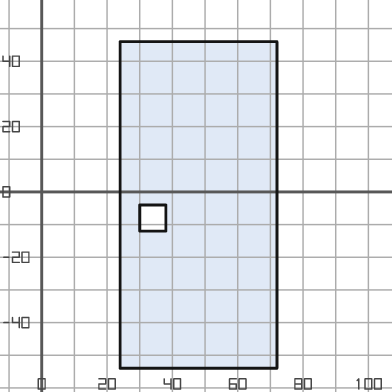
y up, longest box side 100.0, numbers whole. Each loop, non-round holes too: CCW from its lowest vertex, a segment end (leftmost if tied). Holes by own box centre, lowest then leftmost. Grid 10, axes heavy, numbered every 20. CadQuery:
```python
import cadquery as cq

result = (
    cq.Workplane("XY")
    .moveTo(24.0, -54.0)
    .lineTo(72.0, -54.0)
    .lineTo(72.0, 46.0)
    .lineTo(24.0, 46.0)
    .close()
    .moveTo(30.0, -12.0)
    .lineTo(38.0, -12.0)
    .lineTo(38.0, -4.0)
    .lineTo(30.0, -4.0)
    .close()
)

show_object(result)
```